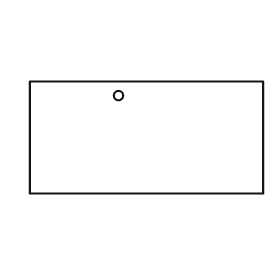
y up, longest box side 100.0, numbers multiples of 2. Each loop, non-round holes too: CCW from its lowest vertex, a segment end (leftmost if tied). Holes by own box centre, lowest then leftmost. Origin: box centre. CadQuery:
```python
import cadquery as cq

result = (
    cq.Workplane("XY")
    .moveTo(-50.0, -24.0)
    .lineTo(50.0, -24.0)
    .lineTo(50.0, 24.0)
    .lineTo(-50.0, 24.0)
    .close()
    .moveTo(-12.0, 18.0)
    .circle(2.0)
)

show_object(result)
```